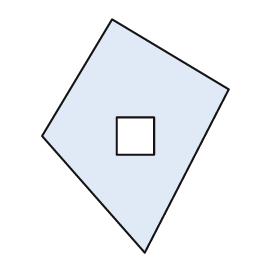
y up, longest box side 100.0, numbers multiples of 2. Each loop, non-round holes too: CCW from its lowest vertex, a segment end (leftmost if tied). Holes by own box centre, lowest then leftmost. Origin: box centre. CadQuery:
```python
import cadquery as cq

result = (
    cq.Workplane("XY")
    .moveTo(4.0, -50.0)
    .lineTo(40.0, 20.0)
    .lineTo(-10.0, 50.0)
    .lineTo(-40.0, 0.0)
    .close()
    .moveTo(-8.0, -8.0)
    .lineTo(8.0, -8.0)
    .lineTo(8.0, 8.0)
    .lineTo(-8.0, 8.0)
    .close()
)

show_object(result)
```